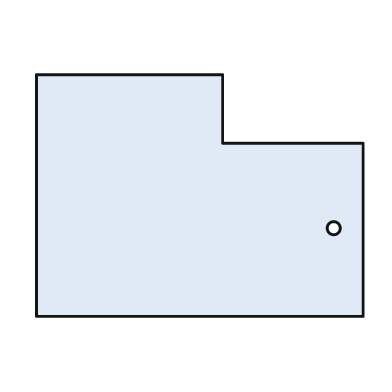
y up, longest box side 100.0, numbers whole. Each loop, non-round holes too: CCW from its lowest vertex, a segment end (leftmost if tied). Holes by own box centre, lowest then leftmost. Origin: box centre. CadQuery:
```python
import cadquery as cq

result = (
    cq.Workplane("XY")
    .moveTo(-50.0, -37.0)
    .lineTo(50.0, -37.0)
    .lineTo(50.0, 16.0)
    .lineTo(7.0, 16.0)
    .lineTo(7.0, 37.0)
    .lineTo(-50.0, 37.0)
    .close()
    .moveTo(41.0, -10.0)
    .circle(2.0)
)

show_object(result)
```